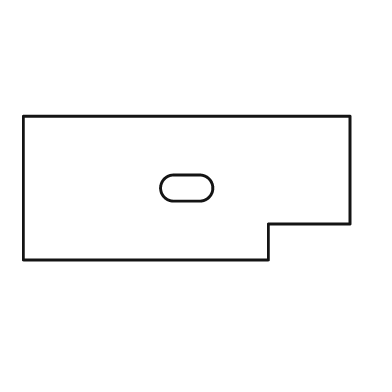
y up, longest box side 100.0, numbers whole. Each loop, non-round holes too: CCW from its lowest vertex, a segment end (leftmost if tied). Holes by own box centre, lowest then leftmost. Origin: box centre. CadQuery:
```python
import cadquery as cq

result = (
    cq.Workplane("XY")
    .moveTo(-50.0, -22.0)
    .lineTo(25.0, -22.0)
    .lineTo(25.0, -11.0)
    .lineTo(50.0, -11.0)
    .lineTo(50.0, 22.0)
    .lineTo(-50.0, 22.0)
    .close()
    .moveTo(-4.0, -4.0)
    .lineTo(4.0, -4.0)
    .threePointArc((8.0, 0.0), (4.0, 4.0))
    .lineTo(-4.0, 4.0)
    .threePointArc((-8.0, 0.0), (-4.0, -4.0))
    .close()
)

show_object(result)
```